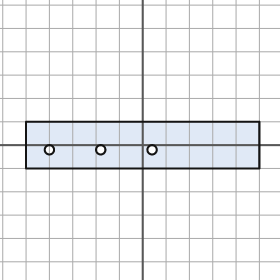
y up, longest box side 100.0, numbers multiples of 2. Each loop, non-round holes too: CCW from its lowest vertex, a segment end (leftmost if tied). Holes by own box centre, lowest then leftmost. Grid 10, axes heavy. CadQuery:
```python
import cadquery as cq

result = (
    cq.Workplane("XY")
    .moveTo(-50.0, -10.0)
    .lineTo(50.0, -10.0)
    .lineTo(50.0, 10.0)
    .lineTo(-50.0, 10.0)
    .close()
    .moveTo(-40.0, -2.0)
    .circle(2.0)
    .moveTo(-18.0, -2.0)
    .circle(2.0)
    .moveTo(4.0, -2.0)
    .circle(2.0)
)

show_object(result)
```